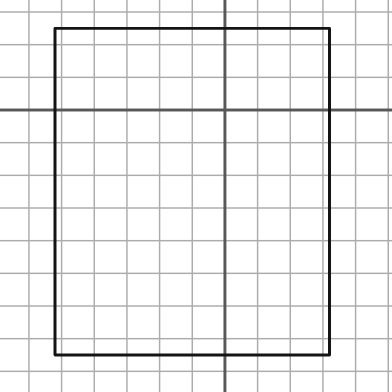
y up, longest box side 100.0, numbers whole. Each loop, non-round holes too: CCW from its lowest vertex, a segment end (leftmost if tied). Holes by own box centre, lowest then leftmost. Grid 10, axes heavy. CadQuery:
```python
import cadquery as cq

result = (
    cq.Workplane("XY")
    .moveTo(-52.0, -75.0)
    .lineTo(32.0, -75.0)
    .lineTo(32.0, 25.0)
    .lineTo(-52.0, 25.0)
    .close()
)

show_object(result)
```